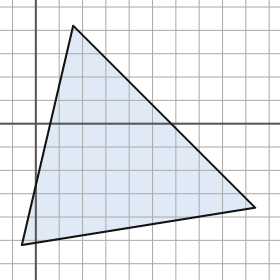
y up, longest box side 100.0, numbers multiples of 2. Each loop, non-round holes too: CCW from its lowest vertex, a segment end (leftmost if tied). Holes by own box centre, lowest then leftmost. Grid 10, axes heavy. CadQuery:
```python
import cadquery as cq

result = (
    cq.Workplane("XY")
    .moveTo(-6.0, -52.0)
    .lineTo(94.0, -36.0)
    .lineTo(16.0, 42.0)
    .close()
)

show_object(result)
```